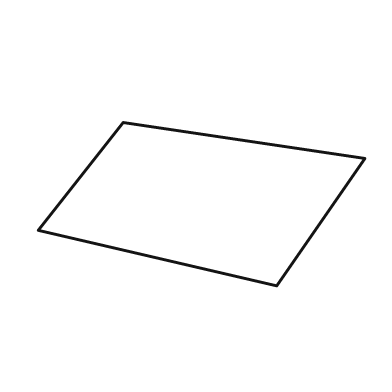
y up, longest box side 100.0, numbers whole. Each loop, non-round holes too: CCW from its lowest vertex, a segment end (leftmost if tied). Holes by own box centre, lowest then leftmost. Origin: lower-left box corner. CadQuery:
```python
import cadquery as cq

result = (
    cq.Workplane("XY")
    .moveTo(73.0, 0.0)
    .lineTo(100.0, 39.0)
    .lineTo(26.0, 50.0)
    .lineTo(0.0, 17.0)
    .close()
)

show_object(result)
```